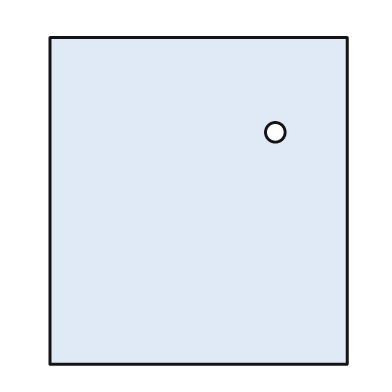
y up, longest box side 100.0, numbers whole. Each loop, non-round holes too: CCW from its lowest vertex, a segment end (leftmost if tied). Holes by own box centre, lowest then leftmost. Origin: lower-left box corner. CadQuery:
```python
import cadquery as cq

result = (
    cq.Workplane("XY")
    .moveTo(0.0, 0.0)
    .lineTo(91.0, 0.0)
    .lineTo(91.0, 100.0)
    .lineTo(0.0, 100.0)
    .close()
    .moveTo(69.0, 71.0)
    .circle(3.0)
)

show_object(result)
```